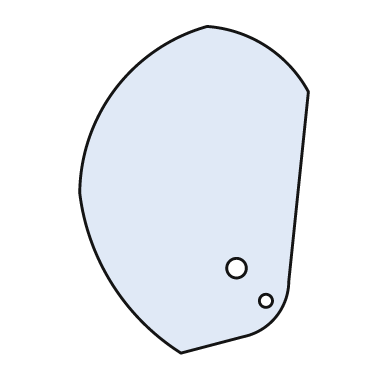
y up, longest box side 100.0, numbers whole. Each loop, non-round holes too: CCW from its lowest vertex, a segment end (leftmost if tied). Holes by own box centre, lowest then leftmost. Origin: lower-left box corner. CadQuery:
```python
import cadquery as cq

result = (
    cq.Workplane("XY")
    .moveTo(31.0, 0.0)
    .lineTo(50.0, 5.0)
    .threePointArc((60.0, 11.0), (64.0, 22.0))
    .lineTo(70.0, 80.0)
    .threePointArc((57.0, 94.0), (39.0, 100.0))
    .threePointArc((11.0, 81.0), (0.0, 49.0))
    .threePointArc((10.0, 21.0), (31.0, 0.0))
    .close()
    .moveTo(57.0, 16.0)
    .circle(2.0)
    .moveTo(48.0, 26.0)
    .circle(3.0)
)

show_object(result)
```